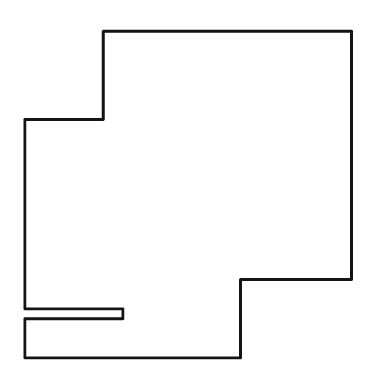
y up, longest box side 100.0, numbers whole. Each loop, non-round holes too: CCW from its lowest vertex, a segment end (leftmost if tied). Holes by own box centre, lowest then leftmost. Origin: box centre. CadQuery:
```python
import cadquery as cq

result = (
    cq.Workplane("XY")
    .moveTo(-50.0, -50.0)
    .lineTo(16.0, -50.0)
    .lineTo(16.0, -26.0)
    .lineTo(50.0, -26.0)
    .lineTo(50.0, 50.0)
    .lineTo(-26.0, 50.0)
    .lineTo(-26.0, 23.0)
    .lineTo(-50.0, 23.0)
    .lineTo(-50.0, -35.0)
    .lineTo(-20.0, -35.0)
    .lineTo(-20.0, -38.0)
    .lineTo(-50.0, -38.0)
    .close()
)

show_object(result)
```